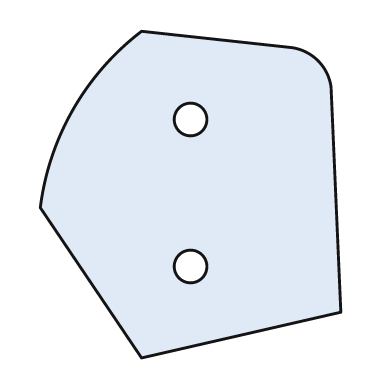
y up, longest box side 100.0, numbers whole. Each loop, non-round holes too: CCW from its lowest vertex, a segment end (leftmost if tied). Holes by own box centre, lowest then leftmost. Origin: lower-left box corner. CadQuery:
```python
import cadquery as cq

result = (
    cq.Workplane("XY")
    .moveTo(31.0, 0.0)
    .lineTo(92.0, 14.0)
    .lineTo(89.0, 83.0)
    .threePointArc((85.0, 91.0), (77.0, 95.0))
    .lineTo(31.0, 100.0)
    .threePointArc((10.0, 76.0), (0.0, 46.0))
    .close()
    .moveTo(46.0, 28.0)
    .circle(5.0)
    .moveTo(46.0, 73.0)
    .circle(5.0)
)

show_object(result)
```